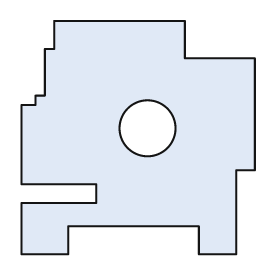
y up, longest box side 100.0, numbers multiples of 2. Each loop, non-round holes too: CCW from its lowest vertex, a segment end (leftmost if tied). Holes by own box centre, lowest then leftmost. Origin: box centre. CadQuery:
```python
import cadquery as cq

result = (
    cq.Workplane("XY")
    .moveTo(-50.0, -50.0)
    .lineTo(-30.0, -50.0)
    .lineTo(-30.0, -38.0)
    .lineTo(26.0, -38.0)
    .lineTo(26.0, -50.0)
    .lineTo(42.0, -50.0)
    .lineTo(42.0, -14.0)
    .lineTo(50.0, -14.0)
    .lineTo(50.0, 34.0)
    .lineTo(20.0, 34.0)
    .lineTo(20.0, 50.0)
    .lineTo(-36.0, 50.0)
    .lineTo(-36.0, 38.0)
    .lineTo(-40.0, 38.0)
    .lineTo(-40.0, 18.0)
    .lineTo(-44.0, 18.0)
    .lineTo(-44.0, 14.0)
    .lineTo(-50.0, 14.0)
    .lineTo(-50.0, -20.0)
    .lineTo(-18.0, -20.0)
    .lineTo(-18.0, -28.0)
    .lineTo(-50.0, -28.0)
    .close()
    .moveTo(4.0, 4.0)
    .circle(12.0)
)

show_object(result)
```